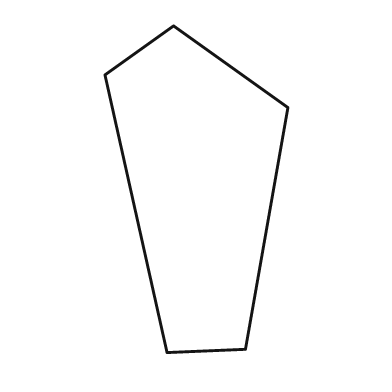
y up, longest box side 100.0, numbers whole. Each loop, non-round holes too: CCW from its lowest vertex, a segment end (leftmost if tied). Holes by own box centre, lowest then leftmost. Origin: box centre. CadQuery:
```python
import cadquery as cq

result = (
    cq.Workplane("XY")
    .moveTo(-9.0, -50.0)
    .lineTo(15.0, -49.0)
    .lineTo(28.0, 25.0)
    .lineTo(-7.0, 50.0)
    .lineTo(-28.0, 35.0)
    .close()
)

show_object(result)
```